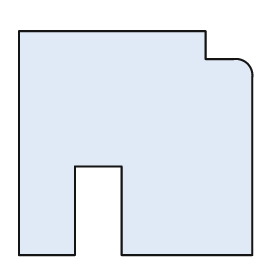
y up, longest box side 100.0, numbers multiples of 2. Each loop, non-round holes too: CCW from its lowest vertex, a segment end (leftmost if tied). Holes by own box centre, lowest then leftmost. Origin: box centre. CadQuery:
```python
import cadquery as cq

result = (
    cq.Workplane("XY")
    .moveTo(-50.0, -48.0)
    .lineTo(-26.0, -48.0)
    .lineTo(-26.0, -10.0)
    .lineTo(-6.0, -10.0)
    .lineTo(-6.0, -48.0)
    .lineTo(50.0, -48.0)
    .lineTo(50.0, 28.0)
    .threePointArc((48.0, 34.0), (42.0, 36.0))
    .lineTo(30.0, 36.0)
    .lineTo(30.0, 48.0)
    .lineTo(-50.0, 48.0)
    .close()
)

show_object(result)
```